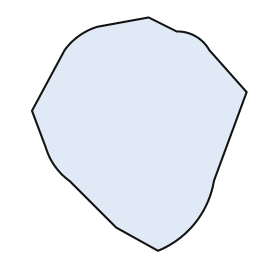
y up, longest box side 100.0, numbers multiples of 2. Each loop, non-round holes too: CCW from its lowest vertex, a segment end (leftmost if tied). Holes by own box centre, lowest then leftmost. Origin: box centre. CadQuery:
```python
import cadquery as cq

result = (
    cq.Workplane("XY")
    .moveTo(8.0, -50.0)
    .threePointArc((24.0, -38.0), (32.0, -20.0))
    .lineTo(46.0, 18.0)
    .lineTo(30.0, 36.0)
    .threePointArc((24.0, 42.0), (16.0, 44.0))
    .lineTo(4.0, 50.0)
    .lineTo(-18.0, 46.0)
    .threePointArc((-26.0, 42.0), (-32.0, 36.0))
    .lineTo(-46.0, 10.0)
    .lineTo(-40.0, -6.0)
    .threePointArc((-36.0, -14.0), (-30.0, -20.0))
    .lineTo(-10.0, -40.0)
    .close()
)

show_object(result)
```